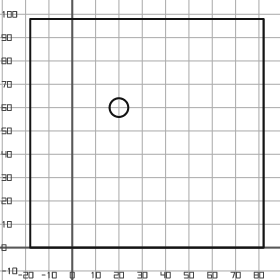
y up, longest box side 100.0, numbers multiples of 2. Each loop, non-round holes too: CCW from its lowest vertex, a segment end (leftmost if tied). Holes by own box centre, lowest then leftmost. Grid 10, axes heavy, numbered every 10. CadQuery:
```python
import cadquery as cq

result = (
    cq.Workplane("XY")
    .moveTo(-18.0, 0.0)
    .lineTo(82.0, 0.0)
    .lineTo(82.0, 98.0)
    .lineTo(-18.0, 98.0)
    .close()
    .moveTo(20.0, 60.0)
    .circle(4.0)
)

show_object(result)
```